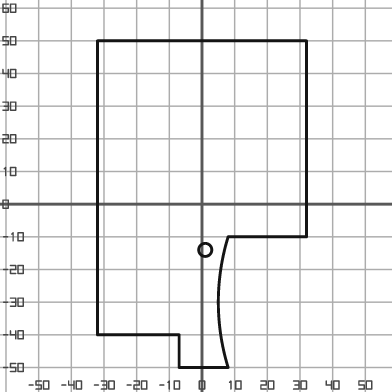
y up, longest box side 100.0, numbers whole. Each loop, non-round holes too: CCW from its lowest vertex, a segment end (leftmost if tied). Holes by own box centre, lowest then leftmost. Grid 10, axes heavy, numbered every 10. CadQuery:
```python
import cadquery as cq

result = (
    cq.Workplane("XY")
    .moveTo(-7.0, -50.0)
    .lineTo(8.0, -50.0)
    .threePointArc((5.0, -30.0), (8.0, -10.0))
    .lineTo(32.0, -10.0)
    .lineTo(32.0, 50.0)
    .lineTo(-32.0, 50.0)
    .lineTo(-32.0, -40.0)
    .lineTo(-7.0, -40.0)
    .close()
    .moveTo(1.0, -14.0)
    .circle(2.0)
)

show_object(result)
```